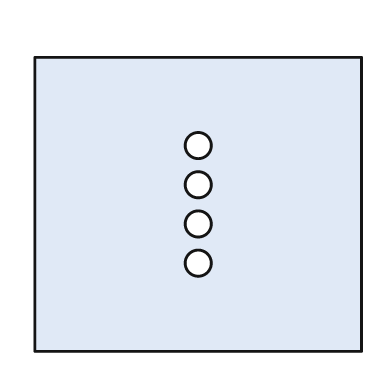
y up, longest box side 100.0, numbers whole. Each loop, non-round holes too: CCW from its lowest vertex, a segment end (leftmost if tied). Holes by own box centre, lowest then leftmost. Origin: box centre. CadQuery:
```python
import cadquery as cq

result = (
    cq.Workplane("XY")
    .moveTo(-50.0, -45.0)
    .lineTo(50.0, -45.0)
    .lineTo(50.0, 45.0)
    .lineTo(-50.0, 45.0)
    .close()
    .moveTo(0.0, -18.0)
    .circle(4.0)
    .moveTo(0.0, -6.0)
    .circle(4.0)
    .moveTo(0.0, 6.0)
    .circle(4.0)
    .moveTo(0.0, 18.0)
    .circle(4.0)
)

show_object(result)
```